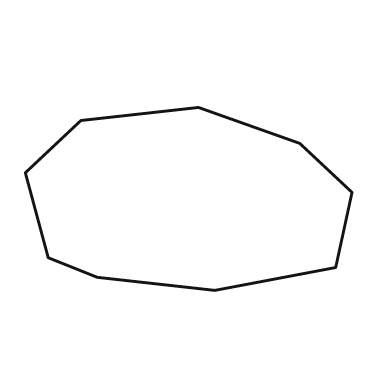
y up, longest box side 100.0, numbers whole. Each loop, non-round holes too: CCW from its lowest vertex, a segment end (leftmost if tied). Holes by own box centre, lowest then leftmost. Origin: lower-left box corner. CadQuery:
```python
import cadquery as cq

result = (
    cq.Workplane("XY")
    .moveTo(58.0, 0.0)
    .lineTo(95.0, 7.0)
    .lineTo(100.0, 30.0)
    .lineTo(84.0, 45.0)
    .lineTo(53.0, 56.0)
    .lineTo(17.0, 52.0)
    .lineTo(0.0, 36.0)
    .lineTo(7.0, 10.0)
    .lineTo(22.0, 4.0)
    .close()
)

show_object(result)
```